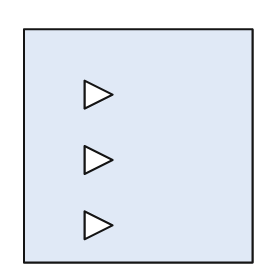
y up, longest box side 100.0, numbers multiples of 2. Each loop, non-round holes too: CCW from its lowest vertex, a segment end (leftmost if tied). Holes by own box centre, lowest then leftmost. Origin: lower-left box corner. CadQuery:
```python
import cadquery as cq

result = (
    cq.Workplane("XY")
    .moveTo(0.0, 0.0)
    .lineTo(98.0, 0.0)
    .lineTo(98.0, 100.0)
    .lineTo(0.0, 100.0)
    .close()
    .moveTo(26.0, 10.0)
    .lineTo(38.0, 16.0)
    .lineTo(26.0, 22.0)
    .close()
    .moveTo(26.0, 38.0)
    .lineTo(38.0, 44.0)
    .lineTo(26.0, 50.0)
    .close()
    .moveTo(26.0, 66.0)
    .lineTo(38.0, 72.0)
    .lineTo(26.0, 78.0)
    .close()
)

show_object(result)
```